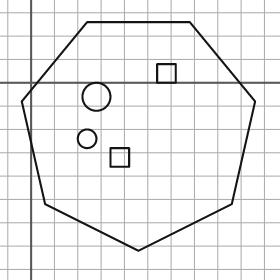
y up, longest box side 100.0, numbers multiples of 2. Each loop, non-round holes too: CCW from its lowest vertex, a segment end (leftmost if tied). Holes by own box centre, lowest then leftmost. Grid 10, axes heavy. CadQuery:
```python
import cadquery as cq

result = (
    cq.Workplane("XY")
    .moveTo(46.0, -72.0)
    .lineTo(86.0, -52.0)
    .lineTo(96.0, -8.0)
    .lineTo(68.0, 26.0)
    .lineTo(24.0, 26.0)
    .lineTo(-4.0, -8.0)
    .lineTo(6.0, -52.0)
    .close()
    .moveTo(34.0, -36.0)
    .lineTo(42.0, -36.0)
    .lineTo(42.0, -28.0)
    .lineTo(34.0, -28.0)
    .close()
    .moveTo(24.0, -24.0)
    .circle(4.0)
    .moveTo(28.0, -6.0)
    .circle(6.0)
    .moveTo(54.0, 0.0)
    .lineTo(62.0, 0.0)
    .lineTo(62.0, 8.0)
    .lineTo(54.0, 8.0)
    .close()
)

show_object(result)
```